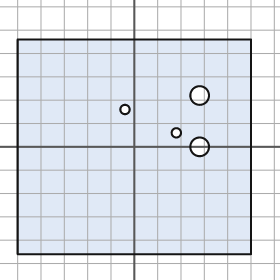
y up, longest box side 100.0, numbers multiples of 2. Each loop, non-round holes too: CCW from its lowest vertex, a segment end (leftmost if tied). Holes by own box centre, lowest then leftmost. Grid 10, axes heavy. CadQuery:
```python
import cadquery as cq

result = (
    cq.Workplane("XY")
    .moveTo(-50.0, -46.0)
    .lineTo(50.0, -46.0)
    .lineTo(50.0, 46.0)
    .lineTo(-50.0, 46.0)
    .close()
    .moveTo(28.0, 0.0)
    .circle(4.0)
    .moveTo(18.0, 6.0)
    .circle(2.0)
    .moveTo(-4.0, 16.0)
    .circle(2.0)
    .moveTo(28.0, 22.0)
    .circle(4.0)
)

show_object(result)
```